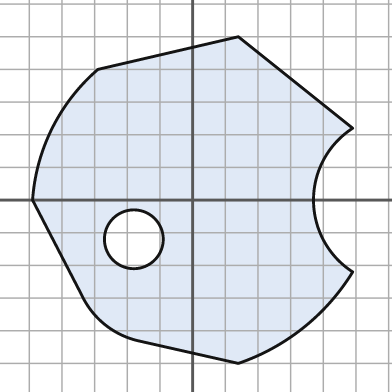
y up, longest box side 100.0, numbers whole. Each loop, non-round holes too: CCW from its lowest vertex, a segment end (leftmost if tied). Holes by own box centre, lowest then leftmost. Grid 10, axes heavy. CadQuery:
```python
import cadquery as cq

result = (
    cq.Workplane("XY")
    .moveTo(14.0, -50.0)
    .threePointArc((34.0, -39.0), (49.0, -22.0))
    .threePointArc((37.0, 0.0), (49.0, 22.0))
    .lineTo(14.0, 50.0)
    .lineTo(-29.0, 40.0)
    .threePointArc((-43.0, 22.0), (-49.0, 0.0))
    .lineTo(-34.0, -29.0)
    .threePointArc((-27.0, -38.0), (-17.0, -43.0))
    .close()
    .moveTo(-18.0, -12.0)
    .circle(9.0)
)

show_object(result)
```